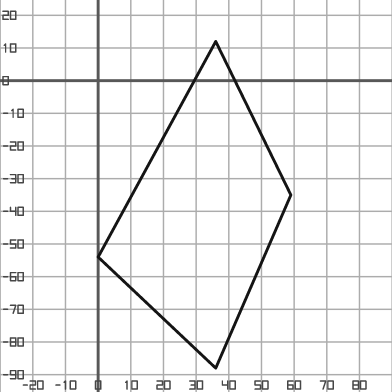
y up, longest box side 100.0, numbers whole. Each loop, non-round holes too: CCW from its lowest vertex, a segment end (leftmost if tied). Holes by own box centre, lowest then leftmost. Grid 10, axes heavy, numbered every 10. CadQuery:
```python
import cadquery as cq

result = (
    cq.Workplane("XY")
    .moveTo(36.0, -88.0)
    .lineTo(59.0, -35.0)
    .lineTo(36.0, 12.0)
    .lineTo(0.0, -54.0)
    .close()
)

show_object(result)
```